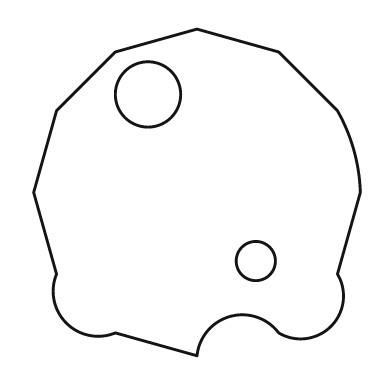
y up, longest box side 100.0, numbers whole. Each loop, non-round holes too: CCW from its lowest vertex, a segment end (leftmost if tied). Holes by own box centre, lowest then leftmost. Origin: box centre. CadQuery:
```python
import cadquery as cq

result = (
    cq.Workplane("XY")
    .moveTo(0.0, -50.0)
    .threePointArc((10.0, -38.0), (25.0, -43.0))
    .threePointArc((41.0, -41.0), (43.0, -25.0))
    .lineTo(50.0, 0.0)
    .threePointArc((48.0, 13.0), (43.0, 25.0))
    .lineTo(25.0, 43.0)
    .lineTo(0.0, 50.0)
    .lineTo(-25.0, 43.0)
    .lineTo(-43.0, 25.0)
    .lineTo(-50.0, 0.0)
    .lineTo(-43.0, -25.0)
    .threePointArc((-40.0, -40.0), (-25.0, -43.0))
    .close()
    .moveTo(18.0, -21.0)
    .circle(6.0)
    .moveTo(-15.0, 30.0)
    .circle(10.0)
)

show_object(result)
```